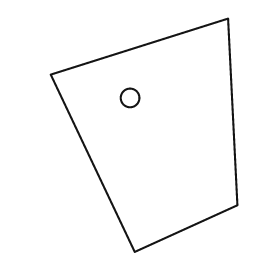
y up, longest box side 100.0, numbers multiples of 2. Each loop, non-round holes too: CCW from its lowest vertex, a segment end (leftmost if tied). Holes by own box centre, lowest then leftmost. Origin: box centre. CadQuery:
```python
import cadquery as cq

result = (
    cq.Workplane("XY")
    .moveTo(-4.0, -50.0)
    .lineTo(40.0, -30.0)
    .lineTo(36.0, 50.0)
    .lineTo(-40.0, 26.0)
    .close()
    .moveTo(-6.0, 16.0)
    .circle(4.0)
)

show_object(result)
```